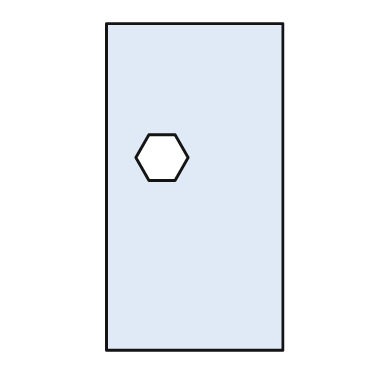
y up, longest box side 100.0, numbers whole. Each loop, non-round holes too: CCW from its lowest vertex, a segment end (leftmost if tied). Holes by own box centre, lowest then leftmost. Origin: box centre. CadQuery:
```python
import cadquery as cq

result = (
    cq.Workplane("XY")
    .moveTo(-27.0, -50.0)
    .lineTo(27.0, -50.0)
    .lineTo(27.0, 50.0)
    .lineTo(-27.0, 50.0)
    .close()
    .moveTo(-14.0, 2.0)
    .lineTo(-6.0, 2.0)
    .lineTo(-2.0, 9.0)
    .lineTo(-6.0, 16.0)
    .lineTo(-14.0, 16.0)
    .lineTo(-18.0, 9.0)
    .close()
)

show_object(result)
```